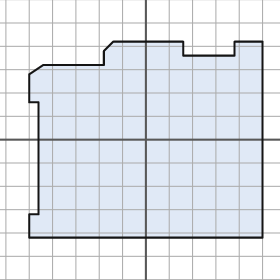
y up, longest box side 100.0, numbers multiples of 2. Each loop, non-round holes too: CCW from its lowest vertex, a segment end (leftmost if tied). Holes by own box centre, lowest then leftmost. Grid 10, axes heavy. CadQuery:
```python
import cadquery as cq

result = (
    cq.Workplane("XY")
    .moveTo(-50.0, -42.0)
    .lineTo(50.0, -42.0)
    .lineTo(50.0, 42.0)
    .lineTo(38.0, 42.0)
    .lineTo(38.0, 36.0)
    .lineTo(16.0, 36.0)
    .lineTo(16.0, 42.0)
    .lineTo(-14.0, 42.0)
    .lineTo(-18.0, 38.0)
    .lineTo(-18.0, 32.0)
    .lineTo(-44.0, 32.0)
    .lineTo(-50.0, 28.0)
    .lineTo(-50.0, 16.0)
    .lineTo(-46.0, 16.0)
    .lineTo(-46.0, -32.0)
    .lineTo(-50.0, -32.0)
    .close()
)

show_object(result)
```